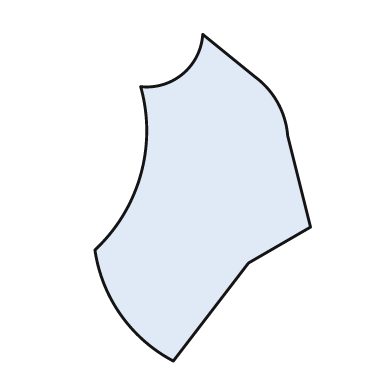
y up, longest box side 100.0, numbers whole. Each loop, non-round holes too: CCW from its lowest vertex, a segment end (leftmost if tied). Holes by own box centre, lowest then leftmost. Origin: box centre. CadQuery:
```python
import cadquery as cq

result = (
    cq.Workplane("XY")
    .moveTo(-9.0, -50.0)
    .lineTo(14.0, -20.0)
    .lineTo(33.0, -9.0)
    .lineTo(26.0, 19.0)
    .threePointArc((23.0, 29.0), (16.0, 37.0))
    .lineTo(0.0, 50.0)
    .threePointArc((-6.0, 38.0), (-19.0, 34.0))
    .threePointArc((-19.0, 7.0), (-33.0, -16.0))
    .threePointArc((-25.0, -36.0), (-9.0, -50.0))
    .close()
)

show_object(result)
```